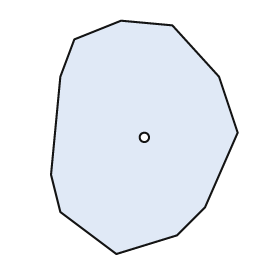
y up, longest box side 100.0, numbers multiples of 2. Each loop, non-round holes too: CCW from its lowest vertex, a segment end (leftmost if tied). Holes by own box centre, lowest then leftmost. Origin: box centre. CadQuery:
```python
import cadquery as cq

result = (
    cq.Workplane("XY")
    .moveTo(-12.0, -50.0)
    .lineTo(14.0, -42.0)
    .lineTo(26.0, -30.0)
    .lineTo(40.0, 2.0)
    .lineTo(32.0, 26.0)
    .lineTo(12.0, 48.0)
    .lineTo(-10.0, 50.0)
    .lineTo(-30.0, 42.0)
    .lineTo(-36.0, 26.0)
    .lineTo(-40.0, -16.0)
    .lineTo(-36.0, -32.0)
    .close()
    .moveTo(0.0, 0.0)
    .circle(2.0)
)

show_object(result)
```